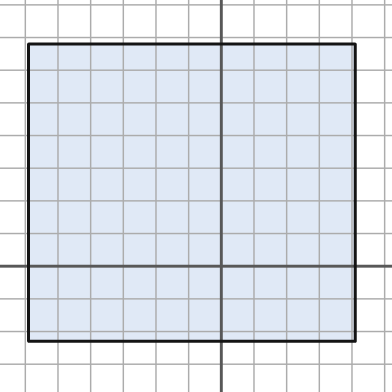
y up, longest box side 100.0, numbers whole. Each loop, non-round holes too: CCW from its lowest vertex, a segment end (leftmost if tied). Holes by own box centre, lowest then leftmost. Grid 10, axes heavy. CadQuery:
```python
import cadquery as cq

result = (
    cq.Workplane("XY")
    .moveTo(-59.0, -23.0)
    .lineTo(41.0, -23.0)
    .lineTo(41.0, 68.0)
    .lineTo(-59.0, 68.0)
    .close()
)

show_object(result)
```